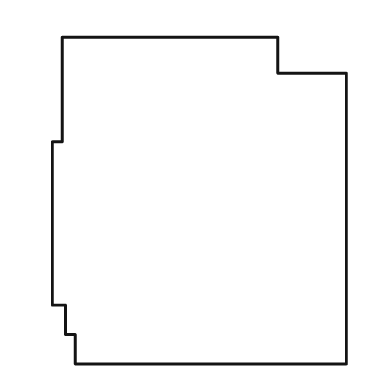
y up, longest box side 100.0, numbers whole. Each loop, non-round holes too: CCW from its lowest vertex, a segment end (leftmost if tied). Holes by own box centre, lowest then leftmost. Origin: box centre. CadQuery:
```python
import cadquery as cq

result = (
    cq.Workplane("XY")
    .moveTo(-38.0, -50.0)
    .lineTo(45.0, -50.0)
    .lineTo(45.0, 39.0)
    .lineTo(24.0, 39.0)
    .lineTo(24.0, 50.0)
    .lineTo(-42.0, 50.0)
    .lineTo(-42.0, 18.0)
    .lineTo(-45.0, 18.0)
    .lineTo(-45.0, -32.0)
    .lineTo(-41.0, -32.0)
    .lineTo(-41.0, -41.0)
    .lineTo(-38.0, -41.0)
    .close()
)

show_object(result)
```